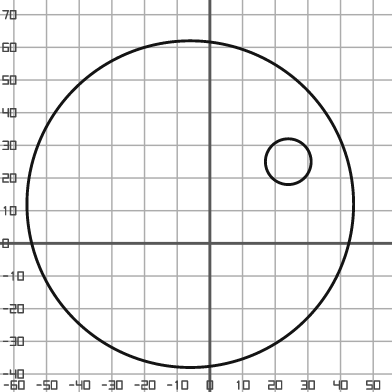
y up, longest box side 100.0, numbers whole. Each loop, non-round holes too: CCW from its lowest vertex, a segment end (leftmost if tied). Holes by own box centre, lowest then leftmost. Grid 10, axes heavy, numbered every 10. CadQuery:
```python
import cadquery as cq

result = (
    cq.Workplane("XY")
    .moveTo(-6.0, 12.0)
    .circle(50.0)
    .moveTo(24.0, 25.0)
    .circle(7.0)
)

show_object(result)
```